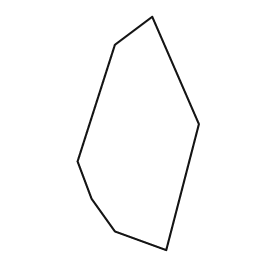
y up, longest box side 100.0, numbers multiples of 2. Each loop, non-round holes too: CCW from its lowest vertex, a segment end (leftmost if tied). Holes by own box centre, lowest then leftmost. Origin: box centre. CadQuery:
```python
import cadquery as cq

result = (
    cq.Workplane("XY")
    .moveTo(12.0, -50.0)
    .lineTo(26.0, 4.0)
    .lineTo(6.0, 50.0)
    .lineTo(-10.0, 38.0)
    .lineTo(-26.0, -12.0)
    .lineTo(-20.0, -28.0)
    .lineTo(-10.0, -42.0)
    .close()
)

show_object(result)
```